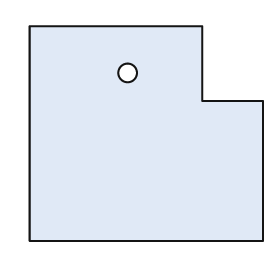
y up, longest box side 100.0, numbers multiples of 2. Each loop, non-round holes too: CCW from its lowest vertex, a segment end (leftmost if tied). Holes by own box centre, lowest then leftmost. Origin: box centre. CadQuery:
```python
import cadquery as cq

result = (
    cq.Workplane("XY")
    .moveTo(-50.0, -46.0)
    .lineTo(50.0, -46.0)
    .lineTo(50.0, 14.0)
    .lineTo(24.0, 14.0)
    .lineTo(24.0, 46.0)
    .lineTo(-50.0, 46.0)
    .close()
    .moveTo(-8.0, 26.0)
    .circle(4.0)
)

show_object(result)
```